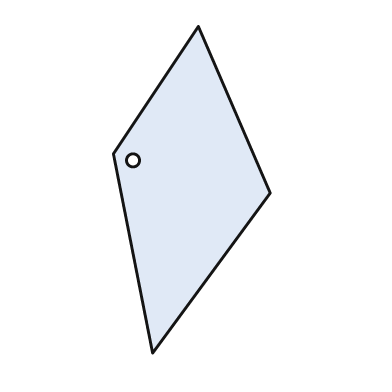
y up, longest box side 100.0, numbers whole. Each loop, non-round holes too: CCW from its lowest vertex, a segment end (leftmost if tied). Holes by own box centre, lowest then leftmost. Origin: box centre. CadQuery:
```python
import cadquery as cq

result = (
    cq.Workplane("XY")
    .moveTo(-12.0, -50.0)
    .lineTo(24.0, -1.0)
    .lineTo(2.0, 50.0)
    .lineTo(-24.0, 11.0)
    .close()
    .moveTo(-18.0, 9.0)
    .circle(2.0)
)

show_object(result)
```